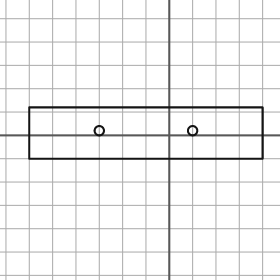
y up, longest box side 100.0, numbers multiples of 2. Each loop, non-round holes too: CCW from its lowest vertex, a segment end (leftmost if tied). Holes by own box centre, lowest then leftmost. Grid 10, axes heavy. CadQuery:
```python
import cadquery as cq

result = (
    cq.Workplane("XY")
    .moveTo(-60.0, -10.0)
    .lineTo(40.0, -10.0)
    .lineTo(40.0, 12.0)
    .lineTo(-60.0, 12.0)
    .close()
    .moveTo(-30.0, 2.0)
    .circle(2.0)
    .moveTo(10.0, 2.0)
    .circle(2.0)
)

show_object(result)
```